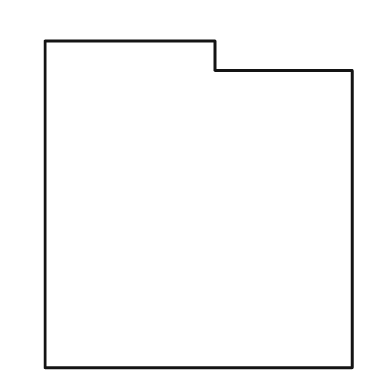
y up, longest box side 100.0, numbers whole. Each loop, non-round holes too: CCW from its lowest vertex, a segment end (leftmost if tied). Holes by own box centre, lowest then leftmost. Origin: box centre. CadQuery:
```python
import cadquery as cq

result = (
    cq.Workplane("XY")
    .moveTo(-47.0, -50.0)
    .lineTo(47.0, -50.0)
    .lineTo(47.0, 41.0)
    .lineTo(5.0, 41.0)
    .lineTo(5.0, 50.0)
    .lineTo(-47.0, 50.0)
    .close()
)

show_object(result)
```